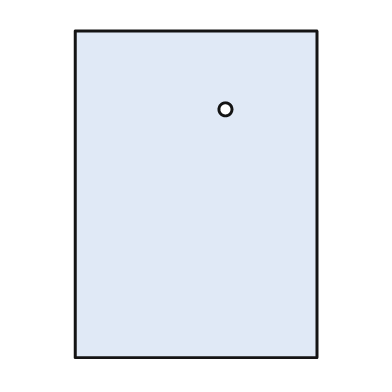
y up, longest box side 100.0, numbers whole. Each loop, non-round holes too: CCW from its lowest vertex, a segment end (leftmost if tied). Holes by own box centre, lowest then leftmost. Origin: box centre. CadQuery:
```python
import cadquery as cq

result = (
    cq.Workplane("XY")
    .moveTo(-37.0, -50.0)
    .lineTo(37.0, -50.0)
    .lineTo(37.0, 50.0)
    .lineTo(-37.0, 50.0)
    .close()
    .moveTo(9.0, 26.0)
    .circle(2.0)
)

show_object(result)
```